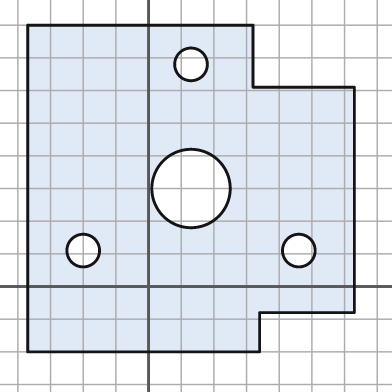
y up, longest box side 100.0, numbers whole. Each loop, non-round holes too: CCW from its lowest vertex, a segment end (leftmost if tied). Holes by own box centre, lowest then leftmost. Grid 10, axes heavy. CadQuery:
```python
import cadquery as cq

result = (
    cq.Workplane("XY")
    .moveTo(-37.0, -20.0)
    .lineTo(34.0, -20.0)
    .lineTo(34.0, -8.0)
    .lineTo(63.0, -8.0)
    .lineTo(63.0, 61.0)
    .lineTo(32.0, 61.0)
    .lineTo(32.0, 80.0)
    .lineTo(-37.0, 80.0)
    .close()
    .moveTo(-20.0, 11.0)
    .circle(5.0)
    .moveTo(46.0, 11.0)
    .circle(5.0)
    .moveTo(13.0, 30.0)
    .circle(12.0)
    .moveTo(13.0, 68.0)
    .circle(5.0)
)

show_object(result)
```